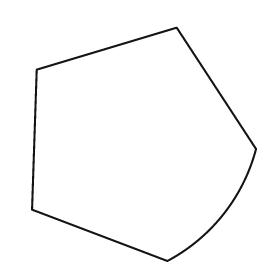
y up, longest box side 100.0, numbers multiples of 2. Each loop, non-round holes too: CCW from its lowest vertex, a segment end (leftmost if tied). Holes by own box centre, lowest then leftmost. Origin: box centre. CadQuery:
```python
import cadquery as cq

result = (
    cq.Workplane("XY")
    .moveTo(10.0, -50.0)
    .threePointArc((34.0, -30.0), (48.0, -2.0))
    .lineTo(14.0, 50.0)
    .lineTo(-46.0, 32.0)
    .lineTo(-48.0, -28.0)
    .close()
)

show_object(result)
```